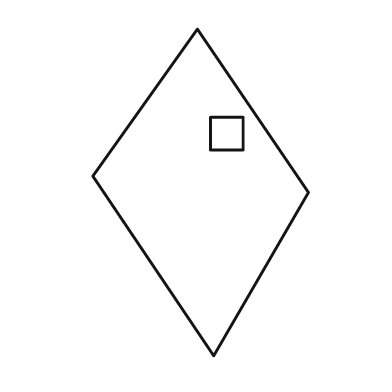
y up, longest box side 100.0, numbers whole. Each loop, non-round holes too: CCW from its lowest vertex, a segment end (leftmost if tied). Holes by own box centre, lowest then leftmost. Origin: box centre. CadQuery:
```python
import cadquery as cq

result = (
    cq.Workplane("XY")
    .moveTo(4.0, -50.0)
    .lineTo(33.0, 0.0)
    .lineTo(-1.0, 50.0)
    .lineTo(-33.0, 5.0)
    .close()
    .moveTo(3.0, 13.0)
    .lineTo(13.0, 13.0)
    .lineTo(13.0, 23.0)
    .lineTo(3.0, 23.0)
    .close()
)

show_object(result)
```